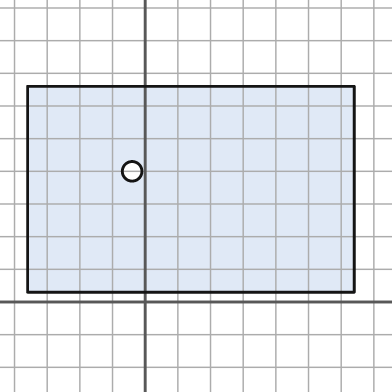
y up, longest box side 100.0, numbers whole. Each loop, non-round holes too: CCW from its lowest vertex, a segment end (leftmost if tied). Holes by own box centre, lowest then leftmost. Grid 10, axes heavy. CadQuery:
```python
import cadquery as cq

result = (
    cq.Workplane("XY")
    .moveTo(-36.0, 3.0)
    .lineTo(64.0, 3.0)
    .lineTo(64.0, 66.0)
    .lineTo(-36.0, 66.0)
    .close()
    .moveTo(-4.0, 40.0)
    .circle(3.0)
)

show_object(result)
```